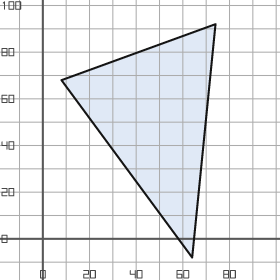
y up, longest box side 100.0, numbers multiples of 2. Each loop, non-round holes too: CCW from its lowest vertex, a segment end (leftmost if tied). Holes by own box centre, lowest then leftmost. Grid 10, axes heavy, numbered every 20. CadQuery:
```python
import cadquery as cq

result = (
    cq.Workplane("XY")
    .moveTo(64.0, -8.0)
    .lineTo(74.0, 92.0)
    .lineTo(8.0, 68.0)
    .close()
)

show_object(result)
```